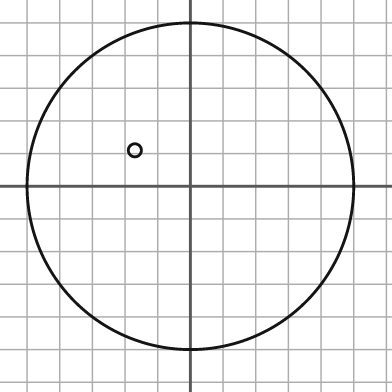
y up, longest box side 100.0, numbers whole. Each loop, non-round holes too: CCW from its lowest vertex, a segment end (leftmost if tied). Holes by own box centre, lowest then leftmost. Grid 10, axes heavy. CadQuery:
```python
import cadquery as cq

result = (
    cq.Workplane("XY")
    .moveTo(0.0, 0.0)
    .circle(50.0)
    .moveTo(-17.0, 11.0)
    .circle(2.0)
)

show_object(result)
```